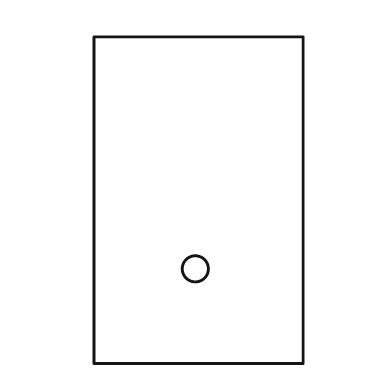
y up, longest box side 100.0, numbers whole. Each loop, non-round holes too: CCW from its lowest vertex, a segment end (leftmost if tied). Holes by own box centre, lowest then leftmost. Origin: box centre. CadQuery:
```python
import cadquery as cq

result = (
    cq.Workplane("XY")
    .moveTo(-32.0, -50.0)
    .lineTo(32.0, -50.0)
    .lineTo(32.0, 50.0)
    .lineTo(-32.0, 50.0)
    .close()
    .moveTo(-1.0, -21.0)
    .circle(4.0)
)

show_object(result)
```